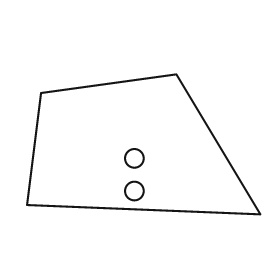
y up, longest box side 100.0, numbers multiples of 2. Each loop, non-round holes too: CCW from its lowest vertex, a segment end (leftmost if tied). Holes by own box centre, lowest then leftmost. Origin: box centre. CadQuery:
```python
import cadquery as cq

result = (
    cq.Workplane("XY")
    .moveTo(50.0, -30.0)
    .lineTo(14.0, 30.0)
    .lineTo(-44.0, 22.0)
    .lineTo(-50.0, -26.0)
    .close()
    .moveTo(-4.0, -20.0)
    .circle(4.0)
    .moveTo(-4.0, -6.0)
    .circle(4.0)
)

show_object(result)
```